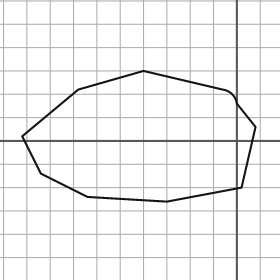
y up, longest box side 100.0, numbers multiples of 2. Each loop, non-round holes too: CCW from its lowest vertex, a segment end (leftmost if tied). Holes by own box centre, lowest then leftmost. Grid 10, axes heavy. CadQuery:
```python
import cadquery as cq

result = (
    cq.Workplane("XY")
    .moveTo(-30.0, -26.0)
    .lineTo(2.0, -20.0)
    .lineTo(8.0, 6.0)
    .lineTo(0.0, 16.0)
    .threePointArc((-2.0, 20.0), (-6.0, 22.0))
    .lineTo(-40.0, 30.0)
    .lineTo(-68.0, 22.0)
    .lineTo(-92.0, 2.0)
    .lineTo(-84.0, -14.0)
    .lineTo(-64.0, -24.0)
    .close()
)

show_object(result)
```